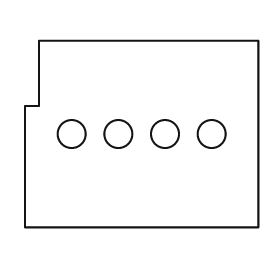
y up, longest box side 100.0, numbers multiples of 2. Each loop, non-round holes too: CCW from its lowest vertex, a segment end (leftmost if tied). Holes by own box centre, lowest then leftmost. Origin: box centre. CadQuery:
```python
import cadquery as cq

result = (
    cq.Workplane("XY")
    .moveTo(-50.0, -40.0)
    .lineTo(50.0, -40.0)
    .lineTo(50.0, 40.0)
    .lineTo(-44.0, 40.0)
    .lineTo(-44.0, 12.0)
    .lineTo(-50.0, 12.0)
    .close()
    .moveTo(-30.0, 0.0)
    .circle(6.0)
    .moveTo(-10.0, 0.0)
    .circle(6.0)
    .moveTo(10.0, 0.0)
    .circle(6.0)
    .moveTo(30.0, 0.0)
    .circle(6.0)
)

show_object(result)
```